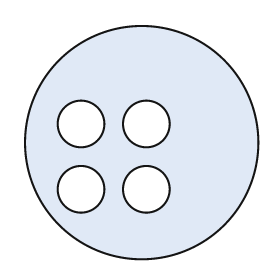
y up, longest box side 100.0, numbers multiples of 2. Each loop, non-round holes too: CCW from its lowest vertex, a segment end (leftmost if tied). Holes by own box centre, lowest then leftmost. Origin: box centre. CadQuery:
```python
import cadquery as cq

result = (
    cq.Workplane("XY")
    .moveTo(0.0, 0.0)
    .circle(50.0)
    .moveTo(-26.0, -20.0)
    .circle(10.0)
    .moveTo(2.0, -20.0)
    .circle(10.0)
    .moveTo(-26.0, 8.0)
    .circle(10.0)
    .moveTo(2.0, 8.0)
    .circle(10.0)
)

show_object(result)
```